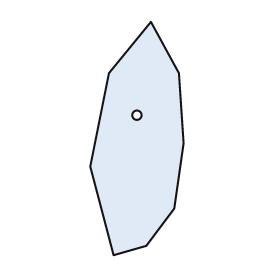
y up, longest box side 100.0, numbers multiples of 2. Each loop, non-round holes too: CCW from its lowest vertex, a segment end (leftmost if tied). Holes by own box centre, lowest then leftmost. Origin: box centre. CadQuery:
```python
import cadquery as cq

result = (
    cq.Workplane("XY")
    .moveTo(-10.0, -50.0)
    .lineTo(4.0, -46.0)
    .lineTo(16.0, -30.0)
    .lineTo(20.0, -2.0)
    .lineTo(18.0, 28.0)
    .lineTo(6.0, 50.0)
    .lineTo(-12.0, 28.0)
    .lineTo(-20.0, -12.0)
    .close()
    .moveTo(0.0, 10.0)
    .circle(2.0)
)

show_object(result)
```